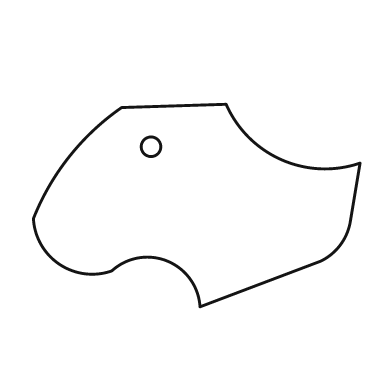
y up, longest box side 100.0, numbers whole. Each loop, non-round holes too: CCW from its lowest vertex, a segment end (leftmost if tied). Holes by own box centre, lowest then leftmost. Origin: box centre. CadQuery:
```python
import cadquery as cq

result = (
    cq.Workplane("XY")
    .moveTo(1.0, -31.0)
    .lineTo(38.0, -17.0)
    .threePointArc((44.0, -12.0), (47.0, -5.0))
    .lineTo(50.0, 13.0)
    .threePointArc((26.0, 14.0), (9.0, 31.0))
    .lineTo(-23.0, 30.0)
    .threePointArc((-39.0, 15.0), (-50.0, -4.0))
    .threePointArc((-42.0, -18.0), (-26.0, -20.0))
    .threePointArc((-9.0, -17.0), (1.0, -31.0))
    .close()
    .moveTo(-14.0, 18.0)
    .circle(3.0)
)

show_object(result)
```